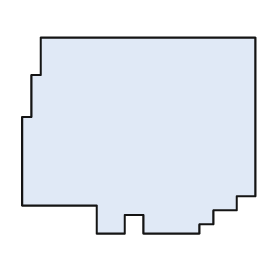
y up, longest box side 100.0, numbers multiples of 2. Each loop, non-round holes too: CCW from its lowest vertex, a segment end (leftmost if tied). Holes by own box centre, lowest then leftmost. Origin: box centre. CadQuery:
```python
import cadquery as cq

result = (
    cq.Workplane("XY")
    .moveTo(-18.0, -42.0)
    .lineTo(-6.0, -42.0)
    .lineTo(-6.0, -34.0)
    .lineTo(2.0, -34.0)
    .lineTo(2.0, -42.0)
    .lineTo(26.0, -42.0)
    .lineTo(26.0, -38.0)
    .lineTo(32.0, -38.0)
    .lineTo(32.0, -32.0)
    .lineTo(42.0, -32.0)
    .lineTo(42.0, -26.0)
    .lineTo(50.0, -26.0)
    .lineTo(50.0, 42.0)
    .lineTo(-42.0, 42.0)
    .lineTo(-42.0, 26.0)
    .lineTo(-46.0, 26.0)
    .lineTo(-46.0, 8.0)
    .lineTo(-50.0, 8.0)
    .lineTo(-50.0, -30.0)
    .lineTo(-18.0, -30.0)
    .close()
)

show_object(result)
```